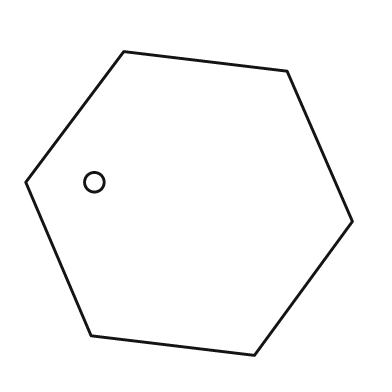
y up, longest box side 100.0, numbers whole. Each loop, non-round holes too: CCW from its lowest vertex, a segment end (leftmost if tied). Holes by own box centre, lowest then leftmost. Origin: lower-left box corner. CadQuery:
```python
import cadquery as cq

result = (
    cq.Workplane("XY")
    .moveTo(70.0, 0.0)
    .lineTo(100.0, 41.0)
    .lineTo(80.0, 87.0)
    .lineTo(30.0, 93.0)
    .lineTo(0.0, 53.0)
    .lineTo(20.0, 6.0)
    .close()
    .moveTo(21.0, 53.0)
    .circle(3.0)
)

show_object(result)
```